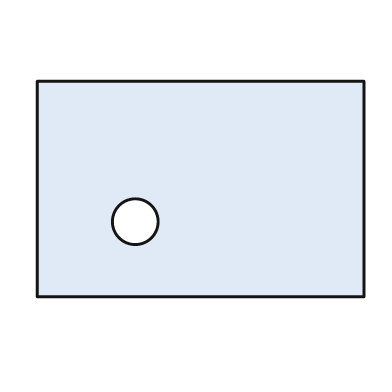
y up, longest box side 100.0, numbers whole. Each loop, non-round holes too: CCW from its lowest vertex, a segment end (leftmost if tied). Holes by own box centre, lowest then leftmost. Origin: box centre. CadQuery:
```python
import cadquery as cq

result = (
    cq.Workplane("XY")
    .moveTo(-50.0, -33.0)
    .lineTo(50.0, -33.0)
    .lineTo(50.0, 33.0)
    .lineTo(-50.0, 33.0)
    .close()
    .moveTo(-20.0, -10.0)
    .circle(7.0)
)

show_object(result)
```